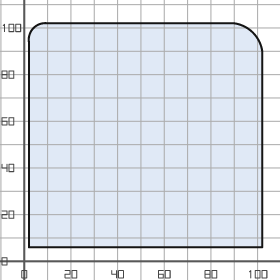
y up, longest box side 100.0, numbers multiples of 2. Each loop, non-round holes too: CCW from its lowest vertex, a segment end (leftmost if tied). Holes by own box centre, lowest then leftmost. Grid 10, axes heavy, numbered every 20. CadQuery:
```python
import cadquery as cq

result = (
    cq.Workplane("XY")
    .moveTo(2.0, 6.0)
    .lineTo(102.0, 6.0)
    .lineTo(102.0, 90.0)
    .threePointArc((98.0, 98.0), (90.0, 102.0))
    .lineTo(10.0, 102.0)
    .threePointArc((4.0, 100.0), (2.0, 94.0))
    .close()
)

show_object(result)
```